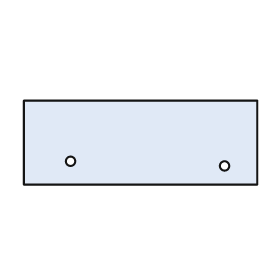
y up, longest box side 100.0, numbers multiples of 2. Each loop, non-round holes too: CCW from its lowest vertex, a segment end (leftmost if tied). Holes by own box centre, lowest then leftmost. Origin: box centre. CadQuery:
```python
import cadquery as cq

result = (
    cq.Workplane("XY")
    .moveTo(-50.0, -18.0)
    .lineTo(50.0, -18.0)
    .lineTo(50.0, 18.0)
    .lineTo(-50.0, 18.0)
    .close()
    .moveTo(36.0, -10.0)
    .circle(2.0)
    .moveTo(-30.0, -8.0)
    .circle(2.0)
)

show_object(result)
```